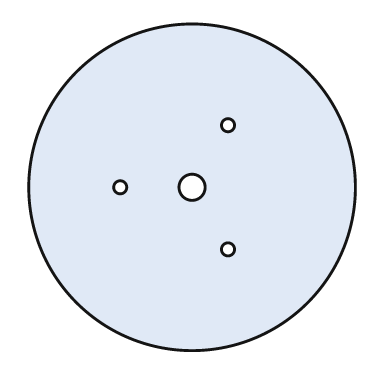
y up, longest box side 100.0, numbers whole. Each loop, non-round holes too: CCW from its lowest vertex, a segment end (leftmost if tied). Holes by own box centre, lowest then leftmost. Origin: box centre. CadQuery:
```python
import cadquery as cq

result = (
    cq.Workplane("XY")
    .moveTo(0.0, 0.0)
    .circle(50.0)
    .moveTo(11.0, -19.0)
    .circle(2.0)
    .moveTo(-22.0, 0.0)
    .circle(2.0)
    .moveTo(0.0, 0.0)
    .circle(4.0)
    .moveTo(11.0, 19.0)
    .circle(2.0)
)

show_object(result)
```